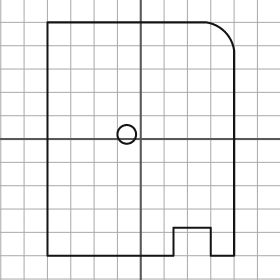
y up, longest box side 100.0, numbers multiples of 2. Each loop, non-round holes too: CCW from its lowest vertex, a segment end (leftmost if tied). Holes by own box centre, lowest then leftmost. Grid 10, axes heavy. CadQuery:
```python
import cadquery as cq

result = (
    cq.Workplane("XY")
    .moveTo(-40.0, -50.0)
    .lineTo(14.0, -50.0)
    .lineTo(14.0, -38.0)
    .lineTo(30.0, -38.0)
    .lineTo(30.0, -50.0)
    .lineTo(40.0, -50.0)
    .lineTo(40.0, 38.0)
    .threePointArc((36.0, 46.0), (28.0, 50.0))
    .lineTo(-40.0, 50.0)
    .close()
    .moveTo(-6.0, 2.0)
    .circle(4.0)
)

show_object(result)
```